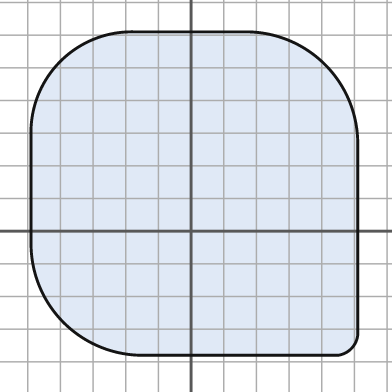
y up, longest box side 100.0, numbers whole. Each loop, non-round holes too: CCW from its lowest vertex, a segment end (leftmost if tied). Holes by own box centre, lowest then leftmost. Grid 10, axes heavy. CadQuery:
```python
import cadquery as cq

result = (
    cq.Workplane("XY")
    .moveTo(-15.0, -38.0)
    .lineTo(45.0, -38.0)
    .threePointArc((49.0, -36.0), (51.0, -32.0))
    .lineTo(51.0, 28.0)
    .threePointArc((41.0, 51.0), (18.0, 61.0))
    .lineTo(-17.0, 61.0)
    .threePointArc((-40.0, 52.0), (-49.0, 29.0))
    .lineTo(-49.0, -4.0)
    .threePointArc((-39.0, -28.0), (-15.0, -38.0))
    .close()
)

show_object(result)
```